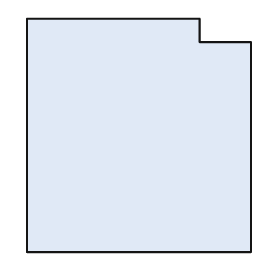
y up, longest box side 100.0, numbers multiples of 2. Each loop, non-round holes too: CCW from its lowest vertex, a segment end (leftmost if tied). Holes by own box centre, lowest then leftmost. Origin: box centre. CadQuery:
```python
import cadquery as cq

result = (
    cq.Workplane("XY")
    .moveTo(-48.0, -50.0)
    .lineTo(48.0, -50.0)
    .lineTo(48.0, 40.0)
    .lineTo(26.0, 40.0)
    .lineTo(26.0, 50.0)
    .lineTo(-48.0, 50.0)
    .close()
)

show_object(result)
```